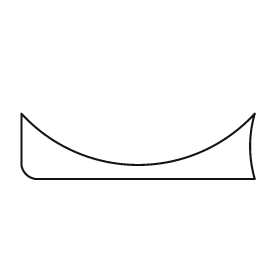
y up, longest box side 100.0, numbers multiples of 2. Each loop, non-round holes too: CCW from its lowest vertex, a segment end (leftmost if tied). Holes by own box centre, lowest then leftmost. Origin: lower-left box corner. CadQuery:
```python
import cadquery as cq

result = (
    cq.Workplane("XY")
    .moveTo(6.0, 0.0)
    .lineTo(100.0, 0.0)
    .threePointArc((98.0, 14.0), (100.0, 28.0))
    .threePointArc((50.0, 6.0), (0.0, 28.0))
    .lineTo(0.0, 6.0)
    .threePointArc((2.0, 2.0), (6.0, 0.0))
    .close()
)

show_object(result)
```